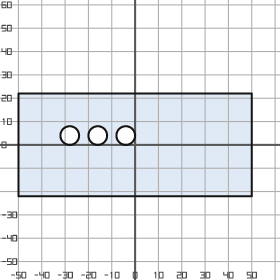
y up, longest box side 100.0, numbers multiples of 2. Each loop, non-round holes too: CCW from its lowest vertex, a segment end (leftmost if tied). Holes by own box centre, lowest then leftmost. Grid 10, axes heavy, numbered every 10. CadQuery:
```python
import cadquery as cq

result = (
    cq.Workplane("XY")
    .moveTo(-50.0, -22.0)
    .lineTo(50.0, -22.0)
    .lineTo(50.0, 22.0)
    .lineTo(-50.0, 22.0)
    .close()
    .moveTo(-28.0, 4.0)
    .circle(4.0)
    .moveTo(-16.0, 4.0)
    .circle(4.0)
    .moveTo(-4.0, 4.0)
    .circle(4.0)
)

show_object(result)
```